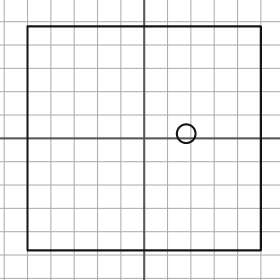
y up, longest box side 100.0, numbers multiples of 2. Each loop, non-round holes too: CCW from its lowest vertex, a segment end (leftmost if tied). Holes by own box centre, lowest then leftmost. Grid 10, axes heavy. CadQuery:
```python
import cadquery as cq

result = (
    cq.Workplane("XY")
    .moveTo(-50.0, -48.0)
    .lineTo(50.0, -48.0)
    .lineTo(50.0, 48.0)
    .lineTo(-50.0, 48.0)
    .close()
    .moveTo(18.0, 2.0)
    .circle(4.0)
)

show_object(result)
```